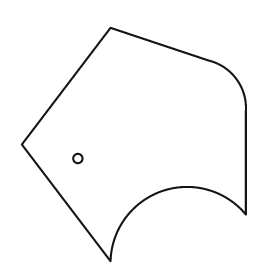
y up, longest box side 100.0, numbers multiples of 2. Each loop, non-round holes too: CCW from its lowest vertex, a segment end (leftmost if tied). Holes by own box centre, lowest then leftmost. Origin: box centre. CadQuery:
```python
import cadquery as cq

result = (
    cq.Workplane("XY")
    .moveTo(-10.0, -50.0)
    .threePointArc((12.0, -20.0), (48.0, -30.0))
    .lineTo(48.0, 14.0)
    .threePointArc((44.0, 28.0), (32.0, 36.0))
    .lineTo(-10.0, 50.0)
    .lineTo(-48.0, 0.0)
    .close()
    .moveTo(-24.0, -6.0)
    .circle(2.0)
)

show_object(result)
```